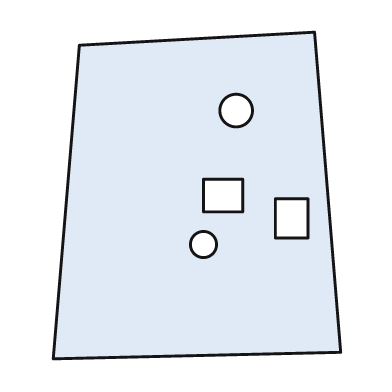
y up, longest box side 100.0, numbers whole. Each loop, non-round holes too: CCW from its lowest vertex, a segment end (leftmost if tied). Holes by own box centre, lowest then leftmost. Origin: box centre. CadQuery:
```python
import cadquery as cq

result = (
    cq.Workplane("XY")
    .moveTo(-44.0, -50.0)
    .lineTo(44.0, -48.0)
    .lineTo(36.0, 50.0)
    .lineTo(-36.0, 46.0)
    .close()
    .moveTo(2.0, -15.0)
    .circle(4.0)
    .moveTo(24.0, -13.0)
    .lineTo(34.0, -13.0)
    .lineTo(34.0, -1.0)
    .lineTo(24.0, -1.0)
    .close()
    .moveTo(2.0, -5.0)
    .lineTo(14.0, -5.0)
    .lineTo(14.0, 5.0)
    .lineTo(2.0, 5.0)
    .close()
    .moveTo(12.0, 26.0)
    .circle(5.0)
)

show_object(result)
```